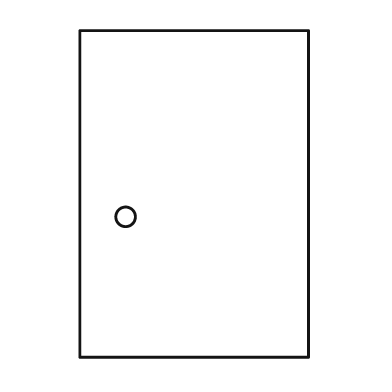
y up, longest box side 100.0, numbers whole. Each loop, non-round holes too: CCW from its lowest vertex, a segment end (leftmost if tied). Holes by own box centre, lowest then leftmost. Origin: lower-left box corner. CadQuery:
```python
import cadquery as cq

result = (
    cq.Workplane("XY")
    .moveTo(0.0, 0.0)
    .lineTo(70.0, 0.0)
    .lineTo(70.0, 100.0)
    .lineTo(0.0, 100.0)
    .close()
    .moveTo(14.0, 43.0)
    .circle(3.0)
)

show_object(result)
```